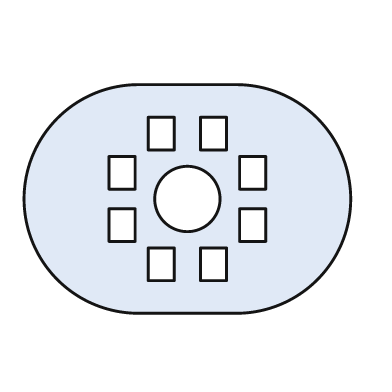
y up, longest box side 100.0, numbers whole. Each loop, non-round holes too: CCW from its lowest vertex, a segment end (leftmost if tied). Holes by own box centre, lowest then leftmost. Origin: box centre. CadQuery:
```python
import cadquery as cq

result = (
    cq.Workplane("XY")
    .moveTo(-15.0, -35.0)
    .lineTo(15.0, -35.0)
    .threePointArc((50.0, 0.0), (15.0, 35.0))
    .lineTo(-15.0, 35.0)
    .threePointArc((-50.0, 0.0), (-15.0, -35.0))
    .close()
    .moveTo(-12.0, -25.0)
    .lineTo(-4.0, -25.0)
    .lineTo(-4.0, -15.0)
    .lineTo(-12.0, -15.0)
    .close()
    .moveTo(4.0, -25.0)
    .lineTo(12.0, -25.0)
    .lineTo(12.0, -15.0)
    .lineTo(4.0, -15.0)
    .close()
    .moveTo(-24.0, -13.0)
    .lineTo(-16.0, -13.0)
    .lineTo(-16.0, -3.0)
    .lineTo(-24.0, -3.0)
    .close()
    .moveTo(16.0, -13.0)
    .lineTo(24.0, -13.0)
    .lineTo(24.0, -3.0)
    .lineTo(16.0, -3.0)
    .close()
    .moveTo(0.0, 0.0)
    .circle(10.0)
    .moveTo(-24.0, 3.0)
    .lineTo(-16.0, 3.0)
    .lineTo(-16.0, 13.0)
    .lineTo(-24.0, 13.0)
    .close()
    .moveTo(16.0, 3.0)
    .lineTo(24.0, 3.0)
    .lineTo(24.0, 13.0)
    .lineTo(16.0, 13.0)
    .close()
    .moveTo(-12.0, 15.0)
    .lineTo(-4.0, 15.0)
    .lineTo(-4.0, 25.0)
    .lineTo(-12.0, 25.0)
    .close()
    .moveTo(4.0, 15.0)
    .lineTo(12.0, 15.0)
    .lineTo(12.0, 25.0)
    .lineTo(4.0, 25.0)
    .close()
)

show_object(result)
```